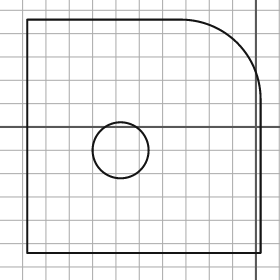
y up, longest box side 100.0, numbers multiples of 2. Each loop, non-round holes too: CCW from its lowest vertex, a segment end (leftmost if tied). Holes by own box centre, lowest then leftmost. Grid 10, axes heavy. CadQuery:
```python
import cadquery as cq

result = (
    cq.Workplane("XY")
    .moveTo(-98.0, -54.0)
    .lineTo(2.0, -54.0)
    .lineTo(2.0, 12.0)
    .threePointArc((-8.0, 36.0), (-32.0, 46.0))
    .lineTo(-98.0, 46.0)
    .close()
    .moveTo(-58.0, -10.0)
    .circle(12.0)
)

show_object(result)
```